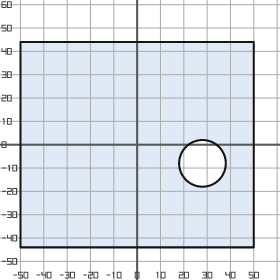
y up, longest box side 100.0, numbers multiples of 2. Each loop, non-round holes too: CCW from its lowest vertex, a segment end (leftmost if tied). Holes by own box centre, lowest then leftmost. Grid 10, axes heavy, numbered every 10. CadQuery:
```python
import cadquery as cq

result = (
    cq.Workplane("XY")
    .moveTo(-50.0, -44.0)
    .lineTo(50.0, -44.0)
    .lineTo(50.0, 44.0)
    .lineTo(-50.0, 44.0)
    .close()
    .moveTo(28.0, -8.0)
    .circle(10.0)
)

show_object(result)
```